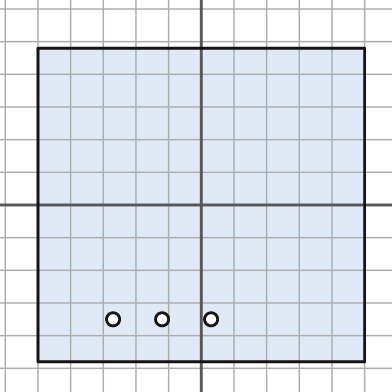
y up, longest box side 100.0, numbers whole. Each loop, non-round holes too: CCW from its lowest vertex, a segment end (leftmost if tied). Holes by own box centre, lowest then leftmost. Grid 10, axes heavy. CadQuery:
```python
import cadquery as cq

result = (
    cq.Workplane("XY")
    .moveTo(-50.0, -48.0)
    .lineTo(50.0, -48.0)
    .lineTo(50.0, 48.0)
    .lineTo(-50.0, 48.0)
    .close()
    .moveTo(-27.0, -35.0)
    .circle(2.0)
    .moveTo(-12.0, -35.0)
    .circle(2.0)
    .moveTo(3.0, -35.0)
    .circle(2.0)
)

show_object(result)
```